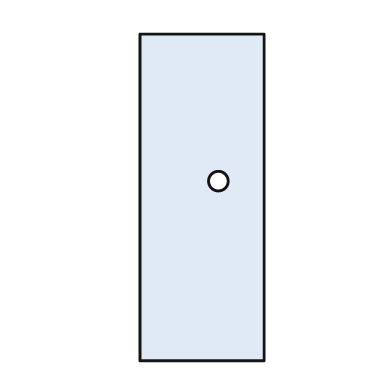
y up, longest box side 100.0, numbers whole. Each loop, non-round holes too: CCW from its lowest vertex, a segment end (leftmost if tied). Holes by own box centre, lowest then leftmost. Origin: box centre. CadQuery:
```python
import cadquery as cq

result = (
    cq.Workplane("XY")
    .moveTo(-19.0, -50.0)
    .lineTo(19.0, -50.0)
    .lineTo(19.0, 50.0)
    .lineTo(-19.0, 50.0)
    .close()
    .moveTo(5.0, 5.0)
    .circle(3.0)
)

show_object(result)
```